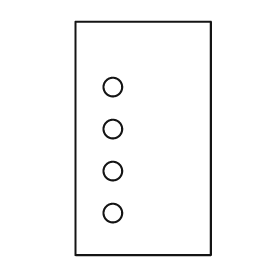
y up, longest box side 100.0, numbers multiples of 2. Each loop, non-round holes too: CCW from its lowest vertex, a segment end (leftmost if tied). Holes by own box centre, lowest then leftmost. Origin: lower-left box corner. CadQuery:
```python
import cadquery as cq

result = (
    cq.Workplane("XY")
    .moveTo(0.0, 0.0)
    .lineTo(58.0, 0.0)
    .lineTo(58.0, 100.0)
    .lineTo(0.0, 100.0)
    .close()
    .moveTo(16.0, 18.0)
    .circle(4.0)
    .moveTo(16.0, 36.0)
    .circle(4.0)
    .moveTo(16.0, 54.0)
    .circle(4.0)
    .moveTo(16.0, 72.0)
    .circle(4.0)
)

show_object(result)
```